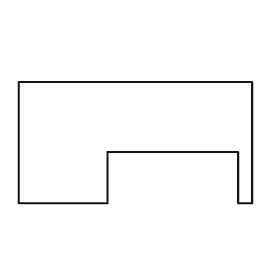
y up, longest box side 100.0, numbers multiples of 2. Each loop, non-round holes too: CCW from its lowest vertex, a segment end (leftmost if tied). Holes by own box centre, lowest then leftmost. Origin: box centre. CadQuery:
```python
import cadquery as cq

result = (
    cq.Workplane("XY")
    .moveTo(-50.0, -26.0)
    .lineTo(-12.0, -26.0)
    .lineTo(-12.0, -4.0)
    .lineTo(44.0, -4.0)
    .lineTo(44.0, -26.0)
    .lineTo(50.0, -26.0)
    .lineTo(50.0, 26.0)
    .lineTo(-50.0, 26.0)
    .close()
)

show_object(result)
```